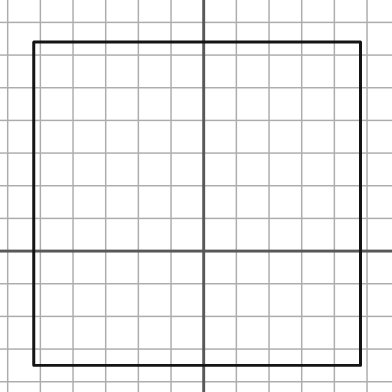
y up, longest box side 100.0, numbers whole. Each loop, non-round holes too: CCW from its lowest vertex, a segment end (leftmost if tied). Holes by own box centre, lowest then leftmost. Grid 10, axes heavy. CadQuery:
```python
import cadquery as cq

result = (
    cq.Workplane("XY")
    .moveTo(-52.0, -35.0)
    .lineTo(48.0, -35.0)
    .lineTo(48.0, 64.0)
    .lineTo(-52.0, 64.0)
    .close()
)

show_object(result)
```